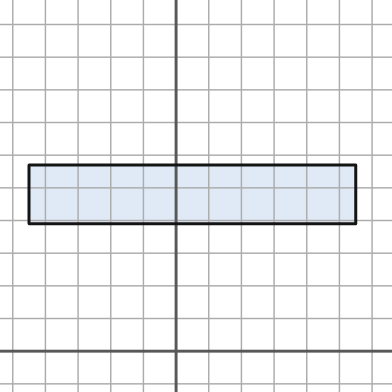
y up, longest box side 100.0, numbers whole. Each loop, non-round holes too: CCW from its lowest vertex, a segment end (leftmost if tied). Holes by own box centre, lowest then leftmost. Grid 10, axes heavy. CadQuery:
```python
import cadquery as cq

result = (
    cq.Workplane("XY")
    .moveTo(-45.0, 39.0)
    .lineTo(55.0, 39.0)
    .lineTo(55.0, 57.0)
    .lineTo(-45.0, 57.0)
    .close()
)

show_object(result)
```